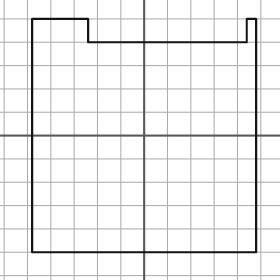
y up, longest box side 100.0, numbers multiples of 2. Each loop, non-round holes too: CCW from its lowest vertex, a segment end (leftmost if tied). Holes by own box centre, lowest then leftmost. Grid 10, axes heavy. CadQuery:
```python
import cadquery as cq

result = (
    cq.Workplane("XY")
    .moveTo(-48.0, -50.0)
    .lineTo(48.0, -50.0)
    .lineTo(48.0, 50.0)
    .lineTo(44.0, 50.0)
    .lineTo(44.0, 40.0)
    .lineTo(-24.0, 40.0)
    .lineTo(-24.0, 50.0)
    .lineTo(-48.0, 50.0)
    .close()
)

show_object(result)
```